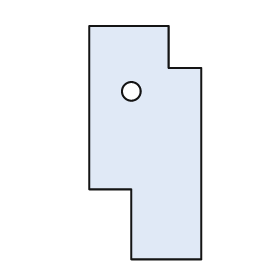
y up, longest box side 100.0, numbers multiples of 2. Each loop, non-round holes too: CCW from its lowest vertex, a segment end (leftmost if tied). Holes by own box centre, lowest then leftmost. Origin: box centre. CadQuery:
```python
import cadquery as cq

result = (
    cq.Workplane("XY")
    .moveTo(-6.0, -50.0)
    .lineTo(24.0, -50.0)
    .lineTo(24.0, 32.0)
    .lineTo(10.0, 32.0)
    .lineTo(10.0, 50.0)
    .lineTo(-24.0, 50.0)
    .lineTo(-24.0, -20.0)
    .lineTo(-6.0, -20.0)
    .close()
    .moveTo(-6.0, 22.0)
    .circle(4.0)
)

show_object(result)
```